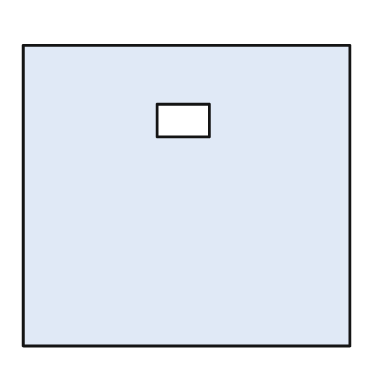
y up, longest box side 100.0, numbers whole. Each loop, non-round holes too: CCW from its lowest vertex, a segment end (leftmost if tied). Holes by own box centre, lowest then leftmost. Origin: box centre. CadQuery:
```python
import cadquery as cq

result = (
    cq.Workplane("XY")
    .moveTo(-50.0, -46.0)
    .lineTo(50.0, -46.0)
    .lineTo(50.0, 46.0)
    .lineTo(-50.0, 46.0)
    .close()
    .moveTo(-9.0, 18.0)
    .lineTo(7.0, 18.0)
    .lineTo(7.0, 28.0)
    .lineTo(-9.0, 28.0)
    .close()
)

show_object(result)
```